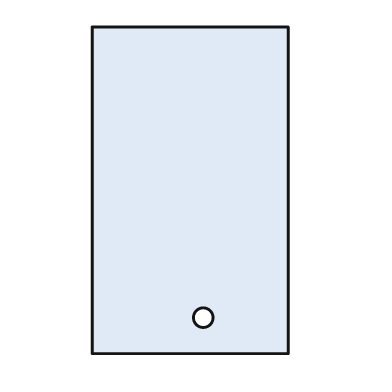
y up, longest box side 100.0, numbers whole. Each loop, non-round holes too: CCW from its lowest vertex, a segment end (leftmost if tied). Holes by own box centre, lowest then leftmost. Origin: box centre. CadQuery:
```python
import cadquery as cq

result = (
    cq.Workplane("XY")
    .moveTo(-30.0, -50.0)
    .lineTo(30.0, -50.0)
    .lineTo(30.0, 50.0)
    .lineTo(-30.0, 50.0)
    .close()
    .moveTo(4.0, -39.0)
    .circle(3.0)
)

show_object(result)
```